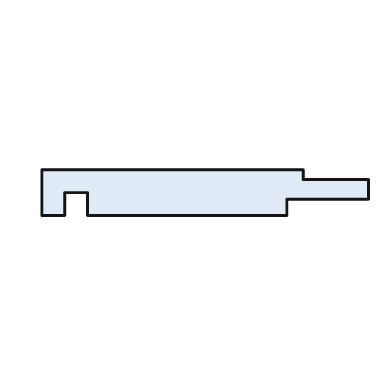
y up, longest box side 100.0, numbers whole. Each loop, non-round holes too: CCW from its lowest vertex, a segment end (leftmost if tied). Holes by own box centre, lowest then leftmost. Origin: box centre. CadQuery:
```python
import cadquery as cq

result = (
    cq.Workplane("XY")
    .moveTo(-50.0, -7.0)
    .lineTo(-43.0, -7.0)
    .lineTo(-43.0, 0.0)
    .lineTo(-36.0, 0.0)
    .lineTo(-36.0, -7.0)
    .lineTo(25.0, -7.0)
    .lineTo(25.0, -2.0)
    .lineTo(50.0, -2.0)
    .lineTo(50.0, 4.0)
    .lineTo(30.0, 4.0)
    .lineTo(30.0, 7.0)
    .lineTo(-50.0, 7.0)
    .close()
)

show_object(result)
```